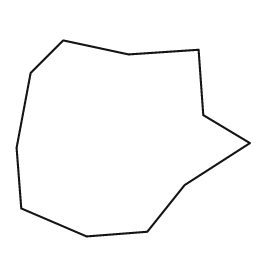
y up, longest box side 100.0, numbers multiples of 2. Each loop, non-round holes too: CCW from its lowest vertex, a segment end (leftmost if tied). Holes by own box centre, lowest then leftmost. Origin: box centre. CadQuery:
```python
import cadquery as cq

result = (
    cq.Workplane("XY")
    .moveTo(-20.0, -42.0)
    .lineTo(6.0, -40.0)
    .lineTo(22.0, -20.0)
    .lineTo(50.0, -2.0)
    .lineTo(30.0, 10.0)
    .lineTo(28.0, 38.0)
    .lineTo(-2.0, 36.0)
    .lineTo(-30.0, 42.0)
    .lineTo(-44.0, 28.0)
    .lineTo(-50.0, -4.0)
    .lineTo(-48.0, -30.0)
    .close()
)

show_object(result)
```